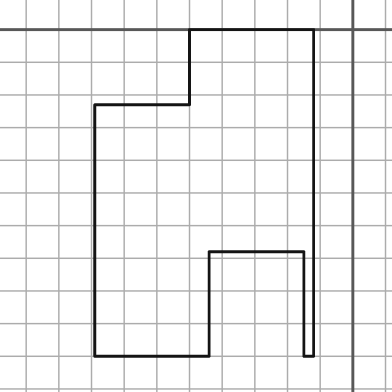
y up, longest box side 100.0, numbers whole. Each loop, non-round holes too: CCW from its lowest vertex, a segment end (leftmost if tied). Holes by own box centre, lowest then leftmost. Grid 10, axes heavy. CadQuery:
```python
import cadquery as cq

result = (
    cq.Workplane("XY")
    .moveTo(-79.0, -100.0)
    .lineTo(-44.0, -100.0)
    .lineTo(-44.0, -68.0)
    .lineTo(-15.0, -68.0)
    .lineTo(-15.0, -100.0)
    .lineTo(-12.0, -100.0)
    .lineTo(-12.0, 0.0)
    .lineTo(-50.0, 0.0)
    .lineTo(-50.0, -23.0)
    .lineTo(-79.0, -23.0)
    .close()
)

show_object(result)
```